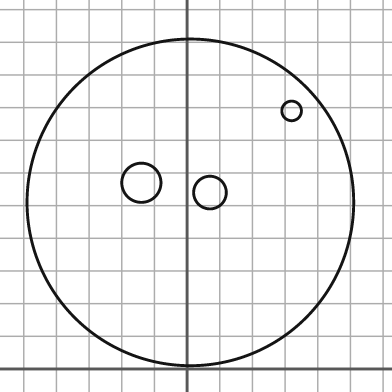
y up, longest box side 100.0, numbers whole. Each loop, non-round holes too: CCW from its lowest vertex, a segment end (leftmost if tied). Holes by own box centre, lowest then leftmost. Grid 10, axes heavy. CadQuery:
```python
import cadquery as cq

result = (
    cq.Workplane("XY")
    .moveTo(1.0, 51.0)
    .circle(50.0)
    .moveTo(7.0, 54.0)
    .circle(5.0)
    .moveTo(-14.0, 57.0)
    .circle(6.0)
    .moveTo(32.0, 79.0)
    .circle(3.0)
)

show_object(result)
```